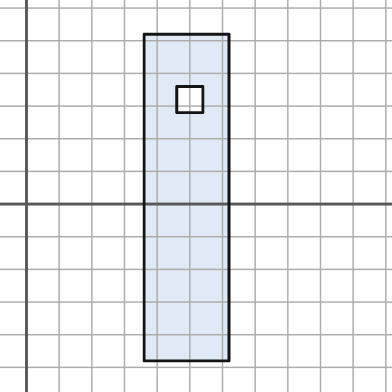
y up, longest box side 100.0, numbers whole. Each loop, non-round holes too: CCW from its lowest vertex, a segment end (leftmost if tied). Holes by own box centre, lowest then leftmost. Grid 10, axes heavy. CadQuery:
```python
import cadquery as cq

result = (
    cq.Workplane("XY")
    .moveTo(36.0, -48.0)
    .lineTo(62.0, -48.0)
    .lineTo(62.0, 52.0)
    .lineTo(36.0, 52.0)
    .close()
    .moveTo(46.0, 28.0)
    .lineTo(54.0, 28.0)
    .lineTo(54.0, 36.0)
    .lineTo(46.0, 36.0)
    .close()
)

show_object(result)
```